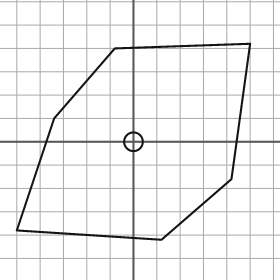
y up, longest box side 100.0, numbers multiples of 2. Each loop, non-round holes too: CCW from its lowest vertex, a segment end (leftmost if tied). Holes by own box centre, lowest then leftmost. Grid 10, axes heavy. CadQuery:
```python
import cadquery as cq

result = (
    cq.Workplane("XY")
    .moveTo(12.0, -42.0)
    .lineTo(42.0, -16.0)
    .lineTo(50.0, 42.0)
    .lineTo(-8.0, 40.0)
    .lineTo(-34.0, 10.0)
    .lineTo(-50.0, -38.0)
    .close()
    .moveTo(0.0, 0.0)
    .circle(4.0)
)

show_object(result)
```